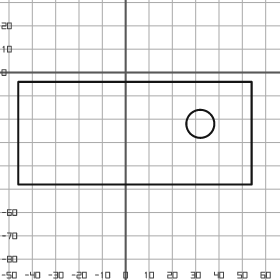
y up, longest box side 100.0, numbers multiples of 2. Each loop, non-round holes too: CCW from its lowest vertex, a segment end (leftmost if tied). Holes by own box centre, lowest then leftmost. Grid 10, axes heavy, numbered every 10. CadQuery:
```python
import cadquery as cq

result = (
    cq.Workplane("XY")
    .moveTo(-46.0, -48.0)
    .lineTo(54.0, -48.0)
    .lineTo(54.0, -4.0)
    .lineTo(-46.0, -4.0)
    .close()
    .moveTo(32.0, -22.0)
    .circle(6.0)
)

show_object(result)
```